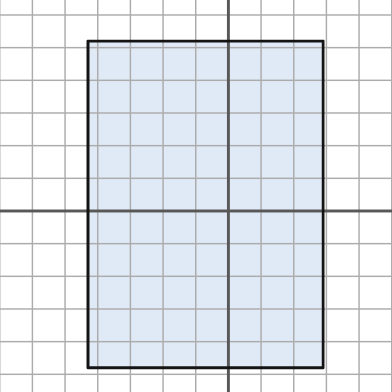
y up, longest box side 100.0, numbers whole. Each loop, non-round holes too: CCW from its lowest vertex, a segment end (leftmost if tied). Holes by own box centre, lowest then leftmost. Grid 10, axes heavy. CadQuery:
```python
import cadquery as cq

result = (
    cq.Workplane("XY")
    .moveTo(-43.0, -48.0)
    .lineTo(29.0, -48.0)
    .lineTo(29.0, 52.0)
    .lineTo(-43.0, 52.0)
    .close()
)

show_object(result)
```